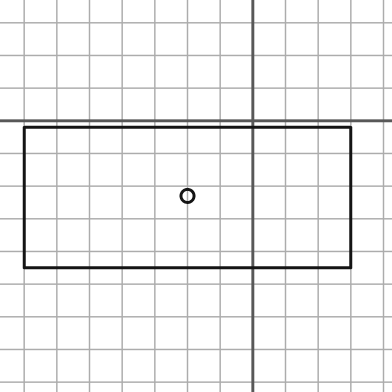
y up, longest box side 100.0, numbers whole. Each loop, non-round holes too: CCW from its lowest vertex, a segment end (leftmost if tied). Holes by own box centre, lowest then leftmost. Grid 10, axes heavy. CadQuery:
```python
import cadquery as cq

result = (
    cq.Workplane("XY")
    .moveTo(-70.0, -45.0)
    .lineTo(30.0, -45.0)
    .lineTo(30.0, -2.0)
    .lineTo(-70.0, -2.0)
    .close()
    .moveTo(-20.0, -23.0)
    .circle(2.0)
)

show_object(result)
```